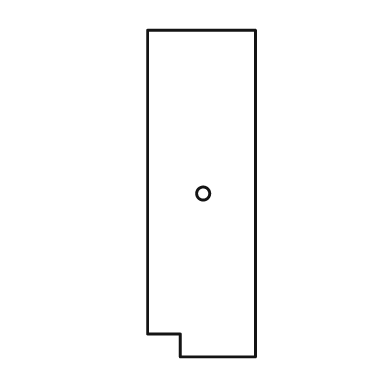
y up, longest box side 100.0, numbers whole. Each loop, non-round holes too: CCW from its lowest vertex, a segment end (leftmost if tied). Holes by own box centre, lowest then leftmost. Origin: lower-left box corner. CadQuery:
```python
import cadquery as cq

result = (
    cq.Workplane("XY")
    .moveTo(10.0, 0.0)
    .lineTo(33.0, 0.0)
    .lineTo(33.0, 100.0)
    .lineTo(0.0, 100.0)
    .lineTo(0.0, 7.0)
    .lineTo(10.0, 7.0)
    .close()
    .moveTo(17.0, 50.0)
    .circle(2.0)
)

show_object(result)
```